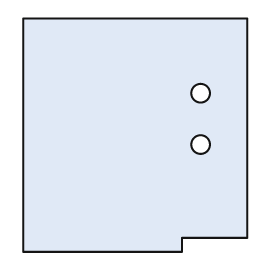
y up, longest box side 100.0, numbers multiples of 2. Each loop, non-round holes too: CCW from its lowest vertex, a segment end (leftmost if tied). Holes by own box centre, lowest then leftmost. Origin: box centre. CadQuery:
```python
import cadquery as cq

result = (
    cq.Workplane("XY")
    .moveTo(-48.0, -50.0)
    .lineTo(20.0, -50.0)
    .lineTo(20.0, -44.0)
    .lineTo(48.0, -44.0)
    .lineTo(48.0, 50.0)
    .lineTo(-48.0, 50.0)
    .close()
    .moveTo(28.0, -4.0)
    .circle(4.0)
    .moveTo(28.0, 18.0)
    .circle(4.0)
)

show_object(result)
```